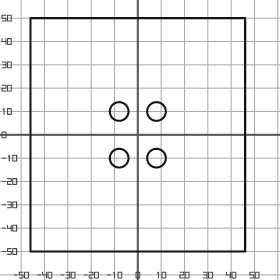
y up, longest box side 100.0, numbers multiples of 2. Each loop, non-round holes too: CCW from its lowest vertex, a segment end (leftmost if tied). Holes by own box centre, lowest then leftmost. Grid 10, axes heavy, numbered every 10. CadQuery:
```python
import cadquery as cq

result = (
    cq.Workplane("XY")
    .moveTo(-46.0, -50.0)
    .lineTo(46.0, -50.0)
    .lineTo(46.0, 50.0)
    .lineTo(-46.0, 50.0)
    .close()
    .moveTo(-8.0, -10.0)
    .circle(4.0)
    .moveTo(8.0, -10.0)
    .circle(4.0)
    .moveTo(-8.0, 10.0)
    .circle(4.0)
    .moveTo(8.0, 10.0)
    .circle(4.0)
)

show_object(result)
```